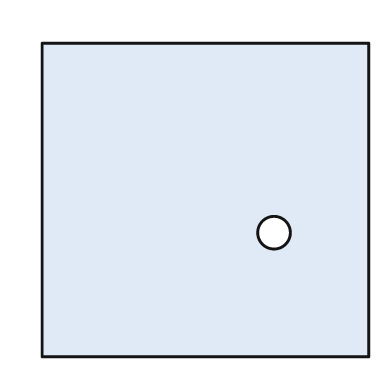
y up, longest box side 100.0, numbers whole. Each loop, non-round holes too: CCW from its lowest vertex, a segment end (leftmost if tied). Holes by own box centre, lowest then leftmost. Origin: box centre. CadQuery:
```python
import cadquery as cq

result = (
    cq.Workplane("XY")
    .moveTo(-50.0, -48.0)
    .lineTo(50.0, -48.0)
    .lineTo(50.0, 48.0)
    .lineTo(-50.0, 48.0)
    .close()
    .moveTo(21.0, -10.0)
    .circle(5.0)
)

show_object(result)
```